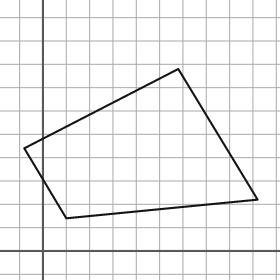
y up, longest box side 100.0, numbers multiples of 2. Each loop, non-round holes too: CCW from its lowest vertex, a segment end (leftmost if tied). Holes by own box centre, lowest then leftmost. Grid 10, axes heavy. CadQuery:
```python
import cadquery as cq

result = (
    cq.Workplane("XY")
    .moveTo(10.0, 14.0)
    .lineTo(92.0, 22.0)
    .lineTo(58.0, 78.0)
    .lineTo(-8.0, 44.0)
    .close()
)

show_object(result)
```